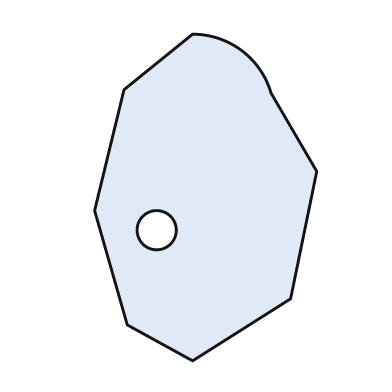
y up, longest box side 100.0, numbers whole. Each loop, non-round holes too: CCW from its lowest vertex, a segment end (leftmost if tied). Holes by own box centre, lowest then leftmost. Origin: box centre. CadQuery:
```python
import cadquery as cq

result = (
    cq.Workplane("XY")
    .moveTo(-4.0, -50.0)
    .lineTo(26.0, -31.0)
    .lineTo(34.0, 8.0)
    .lineTo(20.0, 32.0)
    .threePointArc((11.0, 45.0), (-4.0, 50.0))
    .lineTo(-25.0, 33.0)
    .lineTo(-34.0, -4.0)
    .lineTo(-24.0, -39.0)
    .close()
    .moveTo(-15.0, -10.0)
    .circle(6.0)
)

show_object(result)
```